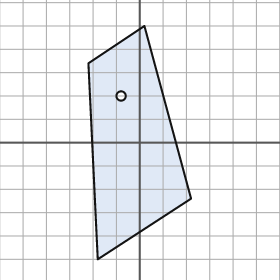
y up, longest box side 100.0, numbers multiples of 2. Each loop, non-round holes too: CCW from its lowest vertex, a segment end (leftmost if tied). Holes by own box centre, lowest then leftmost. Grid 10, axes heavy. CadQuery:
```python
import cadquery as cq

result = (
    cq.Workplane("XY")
    .moveTo(-18.0, -50.0)
    .lineTo(22.0, -24.0)
    .lineTo(2.0, 50.0)
    .lineTo(-22.0, 34.0)
    .close()
    .moveTo(-8.0, 20.0)
    .circle(2.0)
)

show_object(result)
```